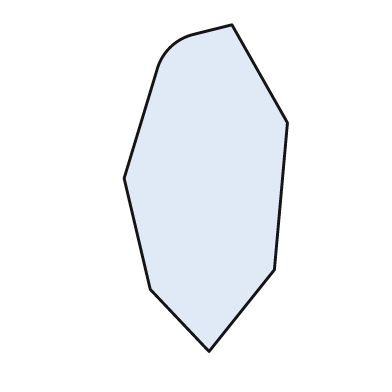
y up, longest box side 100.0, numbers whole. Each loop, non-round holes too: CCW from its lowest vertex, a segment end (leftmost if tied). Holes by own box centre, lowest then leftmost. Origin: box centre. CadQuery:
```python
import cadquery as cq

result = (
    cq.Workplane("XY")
    .moveTo(1.0, -50.0)
    .lineTo(21.0, -25.0)
    .lineTo(25.0, 20.0)
    .lineTo(8.0, 50.0)
    .lineTo(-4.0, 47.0)
    .threePointArc((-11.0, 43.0), (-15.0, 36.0))
    .lineTo(-25.0, 3.0)
    .lineTo(-17.0, -31.0)
    .close()
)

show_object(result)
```